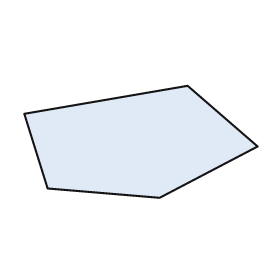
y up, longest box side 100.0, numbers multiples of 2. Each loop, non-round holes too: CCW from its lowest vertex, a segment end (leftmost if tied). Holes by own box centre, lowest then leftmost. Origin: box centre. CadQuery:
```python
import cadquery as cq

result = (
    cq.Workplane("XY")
    .moveTo(8.0, -24.0)
    .lineTo(50.0, -2.0)
    .lineTo(20.0, 24.0)
    .lineTo(-50.0, 12.0)
    .lineTo(-40.0, -20.0)
    .close()
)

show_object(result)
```